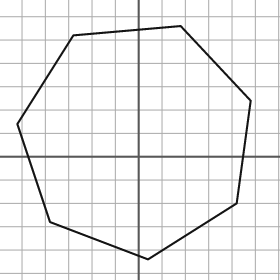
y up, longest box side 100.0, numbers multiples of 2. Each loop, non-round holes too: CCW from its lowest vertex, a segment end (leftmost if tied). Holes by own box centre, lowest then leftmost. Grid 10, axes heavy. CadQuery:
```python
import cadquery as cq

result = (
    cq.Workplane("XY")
    .moveTo(4.0, -44.0)
    .lineTo(42.0, -20.0)
    .lineTo(48.0, 24.0)
    .lineTo(18.0, 56.0)
    .lineTo(-28.0, 52.0)
    .lineTo(-52.0, 14.0)
    .lineTo(-38.0, -28.0)
    .close()
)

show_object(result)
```